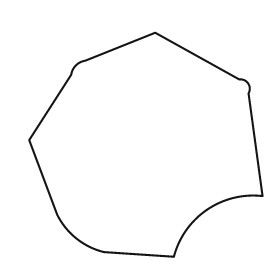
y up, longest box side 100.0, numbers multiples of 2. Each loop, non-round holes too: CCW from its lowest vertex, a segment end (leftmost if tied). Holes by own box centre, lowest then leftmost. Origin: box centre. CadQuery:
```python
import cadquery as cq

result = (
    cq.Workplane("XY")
    .moveTo(12.0, -48.0)
    .threePointArc((26.0, -28.0), (50.0, -22.0))
    .lineTo(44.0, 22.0)
    .threePointArc((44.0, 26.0), (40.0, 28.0))
    .lineTo(4.0, 48.0)
    .lineTo(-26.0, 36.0)
    .threePointArc((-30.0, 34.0), (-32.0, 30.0))
    .lineTo(-50.0, 2.0)
    .lineTo(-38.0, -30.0)
    .threePointArc((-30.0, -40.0), (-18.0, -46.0))
    .close()
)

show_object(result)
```